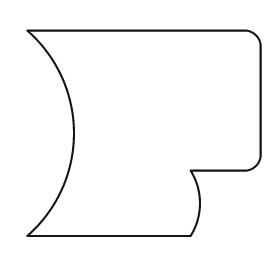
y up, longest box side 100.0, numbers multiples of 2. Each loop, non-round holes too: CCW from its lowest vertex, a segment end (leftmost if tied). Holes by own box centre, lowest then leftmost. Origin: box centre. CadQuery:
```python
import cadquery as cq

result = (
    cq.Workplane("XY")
    .moveTo(-50.0, -44.0)
    .lineTo(20.0, -44.0)
    .threePointArc((24.0, -30.0), (20.0, -16.0))
    .lineTo(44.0, -16.0)
    .threePointArc((48.0, -14.0), (50.0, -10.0))
    .lineTo(50.0, 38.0)
    .threePointArc((48.0, 42.0), (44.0, 44.0))
    .lineTo(-50.0, 44.0)
    .threePointArc((-30.0, 0.0), (-50.0, -44.0))
    .close()
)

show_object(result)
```